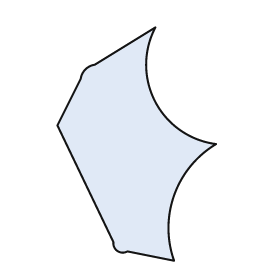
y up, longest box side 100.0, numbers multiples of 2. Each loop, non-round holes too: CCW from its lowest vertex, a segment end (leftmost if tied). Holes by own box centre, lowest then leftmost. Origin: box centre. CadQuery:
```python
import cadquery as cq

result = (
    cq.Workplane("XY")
    .moveTo(16.0, -50.0)
    .threePointArc((16.0, -22.0), (34.0, 0.0))
    .threePointArc((8.0, 18.0), (8.0, 50.0))
    .lineTo(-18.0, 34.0)
    .threePointArc((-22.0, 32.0), (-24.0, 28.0))
    .lineTo(-34.0, 8.0)
    .lineTo(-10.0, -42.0)
    .threePointArc((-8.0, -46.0), (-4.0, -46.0))
    .close()
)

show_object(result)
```